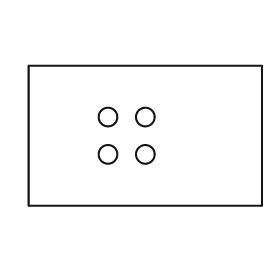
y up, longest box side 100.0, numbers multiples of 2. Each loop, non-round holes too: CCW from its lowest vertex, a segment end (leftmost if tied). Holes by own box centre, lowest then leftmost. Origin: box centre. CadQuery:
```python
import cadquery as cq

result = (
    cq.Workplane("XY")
    .moveTo(-50.0, -30.0)
    .lineTo(50.0, -30.0)
    .lineTo(50.0, 30.0)
    .lineTo(-50.0, 30.0)
    .close()
    .moveTo(-16.0, -8.0)
    .circle(4.0)
    .moveTo(0.0, -8.0)
    .circle(4.0)
    .moveTo(-16.0, 8.0)
    .circle(4.0)
    .moveTo(0.0, 8.0)
    .circle(4.0)
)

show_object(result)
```